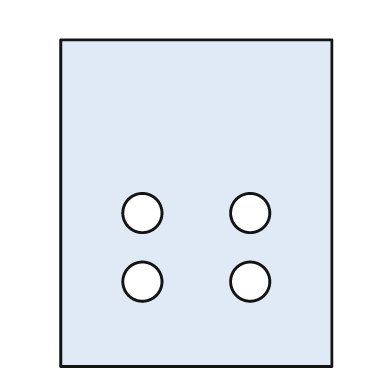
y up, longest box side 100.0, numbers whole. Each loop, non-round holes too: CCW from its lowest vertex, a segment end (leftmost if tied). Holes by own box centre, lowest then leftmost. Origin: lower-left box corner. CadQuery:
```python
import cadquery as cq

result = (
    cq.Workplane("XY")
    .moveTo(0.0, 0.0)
    .lineTo(83.0, 0.0)
    .lineTo(83.0, 100.0)
    .lineTo(0.0, 100.0)
    .close()
    .moveTo(25.0, 26.0)
    .circle(6.0)
    .moveTo(58.0, 26.0)
    .circle(6.0)
    .moveTo(25.0, 47.0)
    .circle(6.0)
    .moveTo(58.0, 47.0)
    .circle(6.0)
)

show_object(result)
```